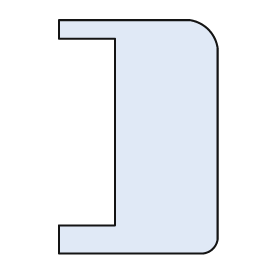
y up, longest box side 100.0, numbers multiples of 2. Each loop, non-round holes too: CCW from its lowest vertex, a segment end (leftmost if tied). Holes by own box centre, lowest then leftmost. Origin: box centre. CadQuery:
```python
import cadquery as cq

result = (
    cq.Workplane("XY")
    .moveTo(-34.0, -50.0)
    .lineTo(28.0, -50.0)
    .threePointArc((32.0, -48.0), (34.0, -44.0))
    .lineTo(34.0, 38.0)
    .threePointArc((30.0, 46.0), (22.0, 50.0))
    .lineTo(-34.0, 50.0)
    .lineTo(-34.0, 42.0)
    .lineTo(-10.0, 42.0)
    .lineTo(-10.0, -38.0)
    .lineTo(-34.0, -38.0)
    .close()
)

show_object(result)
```